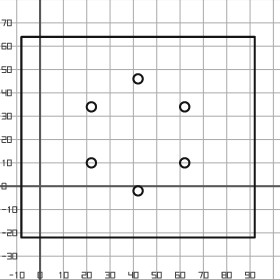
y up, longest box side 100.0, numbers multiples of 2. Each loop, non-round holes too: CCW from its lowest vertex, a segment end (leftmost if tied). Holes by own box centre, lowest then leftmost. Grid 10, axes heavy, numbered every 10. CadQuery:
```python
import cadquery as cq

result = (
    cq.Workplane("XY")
    .moveTo(-8.0, -22.0)
    .lineTo(92.0, -22.0)
    .lineTo(92.0, 64.0)
    .lineTo(-8.0, 64.0)
    .close()
    .moveTo(42.0, -2.0)
    .circle(2.0)
    .moveTo(22.0, 10.0)
    .circle(2.0)
    .moveTo(62.0, 10.0)
    .circle(2.0)
    .moveTo(22.0, 34.0)
    .circle(2.0)
    .moveTo(62.0, 34.0)
    .circle(2.0)
    .moveTo(42.0, 46.0)
    .circle(2.0)
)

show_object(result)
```